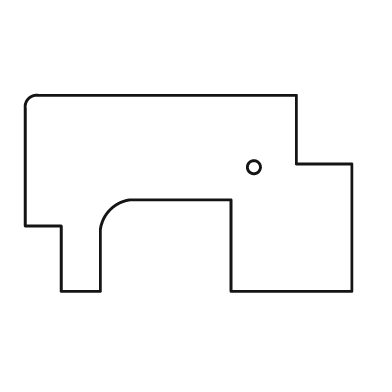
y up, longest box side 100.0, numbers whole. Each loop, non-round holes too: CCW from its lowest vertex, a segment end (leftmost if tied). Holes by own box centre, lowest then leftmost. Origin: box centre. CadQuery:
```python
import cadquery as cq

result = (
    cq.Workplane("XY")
    .moveTo(-39.0, -30.0)
    .lineTo(-27.0, -30.0)
    .lineTo(-27.0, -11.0)
    .threePointArc((-24.0, -5.0), (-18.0, -2.0))
    .lineTo(13.0, -2.0)
    .lineTo(13.0, -30.0)
    .lineTo(50.0, -30.0)
    .lineTo(50.0, 9.0)
    .lineTo(33.0, 9.0)
    .lineTo(33.0, 30.0)
    .lineTo(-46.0, 30.0)
    .threePointArc((-49.0, 29.0), (-50.0, 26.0))
    .lineTo(-50.0, -10.0)
    .lineTo(-39.0, -10.0)
    .close()
    .moveTo(20.0, 8.0)
    .circle(2.0)
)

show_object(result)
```